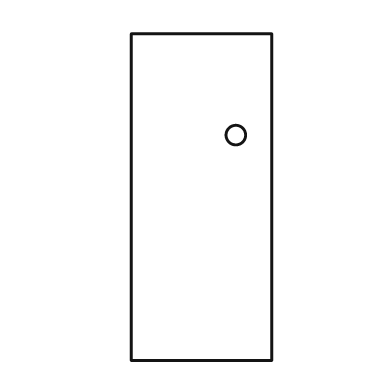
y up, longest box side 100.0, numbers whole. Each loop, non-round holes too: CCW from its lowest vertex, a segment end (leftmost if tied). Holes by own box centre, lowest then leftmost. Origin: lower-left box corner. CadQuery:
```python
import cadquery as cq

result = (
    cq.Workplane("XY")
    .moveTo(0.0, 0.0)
    .lineTo(43.0, 0.0)
    .lineTo(43.0, 100.0)
    .lineTo(0.0, 100.0)
    .close()
    .moveTo(32.0, 69.0)
    .circle(3.0)
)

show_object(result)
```